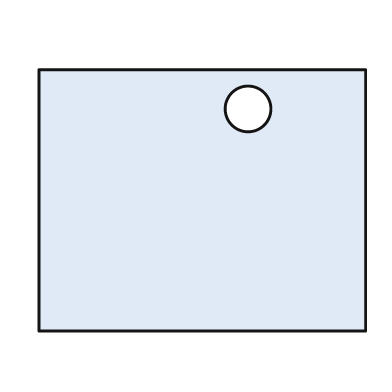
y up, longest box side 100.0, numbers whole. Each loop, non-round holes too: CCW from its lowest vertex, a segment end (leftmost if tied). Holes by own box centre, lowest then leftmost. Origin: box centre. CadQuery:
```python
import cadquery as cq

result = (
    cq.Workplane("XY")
    .moveTo(-50.0, -40.0)
    .lineTo(50.0, -40.0)
    .lineTo(50.0, 40.0)
    .lineTo(-50.0, 40.0)
    .close()
    .moveTo(14.0, 28.0)
    .circle(7.0)
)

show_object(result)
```